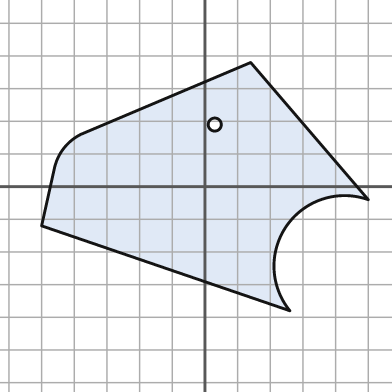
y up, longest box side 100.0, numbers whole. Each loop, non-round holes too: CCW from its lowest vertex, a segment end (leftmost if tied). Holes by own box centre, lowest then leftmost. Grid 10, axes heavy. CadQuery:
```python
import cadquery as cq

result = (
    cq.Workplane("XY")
    .moveTo(26.0, -38.0)
    .threePointArc((25.0, -12.0), (50.0, -4.0))
    .lineTo(14.0, 38.0)
    .lineTo(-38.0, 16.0)
    .threePointArc((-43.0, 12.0), (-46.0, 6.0))
    .lineTo(-50.0, -12.0)
    .close()
    .moveTo(3.0, 19.0)
    .circle(2.0)
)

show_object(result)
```